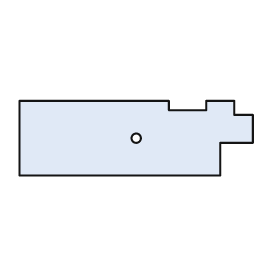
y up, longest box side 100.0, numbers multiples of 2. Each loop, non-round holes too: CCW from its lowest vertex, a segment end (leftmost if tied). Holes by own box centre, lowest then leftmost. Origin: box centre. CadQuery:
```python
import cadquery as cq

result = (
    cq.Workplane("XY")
    .moveTo(-50.0, -16.0)
    .lineTo(36.0, -16.0)
    .lineTo(36.0, -2.0)
    .lineTo(50.0, -2.0)
    .lineTo(50.0, 10.0)
    .lineTo(42.0, 10.0)
    .lineTo(42.0, 16.0)
    .lineTo(30.0, 16.0)
    .lineTo(30.0, 12.0)
    .lineTo(14.0, 12.0)
    .lineTo(14.0, 16.0)
    .lineTo(-50.0, 16.0)
    .close()
    .moveTo(0.0, 0.0)
    .circle(2.0)
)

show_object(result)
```